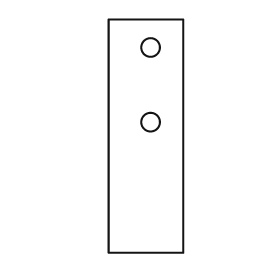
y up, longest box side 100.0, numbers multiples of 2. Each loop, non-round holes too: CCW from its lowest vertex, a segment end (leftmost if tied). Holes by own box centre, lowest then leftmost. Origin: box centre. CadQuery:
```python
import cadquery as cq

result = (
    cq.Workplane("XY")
    .moveTo(-16.0, -50.0)
    .lineTo(16.0, -50.0)
    .lineTo(16.0, 50.0)
    .lineTo(-16.0, 50.0)
    .close()
    .moveTo(2.0, 6.0)
    .circle(4.0)
    .moveTo(2.0, 38.0)
    .circle(4.0)
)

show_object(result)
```